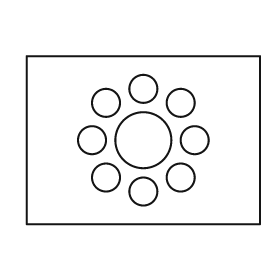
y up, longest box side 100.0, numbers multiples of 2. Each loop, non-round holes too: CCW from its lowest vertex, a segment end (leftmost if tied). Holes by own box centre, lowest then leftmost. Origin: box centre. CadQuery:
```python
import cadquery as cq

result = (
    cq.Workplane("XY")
    .moveTo(-50.0, -36.0)
    .lineTo(50.0, -36.0)
    .lineTo(50.0, 36.0)
    .lineTo(-50.0, 36.0)
    .close()
    .moveTo(0.0, -22.0)
    .circle(6.0)
    .moveTo(-16.0, -16.0)
    .circle(6.0)
    .moveTo(16.0, -16.0)
    .circle(6.0)
    .moveTo(-22.0, 0.0)
    .circle(6.0)
    .moveTo(0.0, 0.0)
    .circle(12.0)
    .moveTo(22.0, 0.0)
    .circle(6.0)
    .moveTo(-16.0, 16.0)
    .circle(6.0)
    .moveTo(16.0, 16.0)
    .circle(6.0)
    .moveTo(0.0, 22.0)
    .circle(6.0)
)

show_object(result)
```